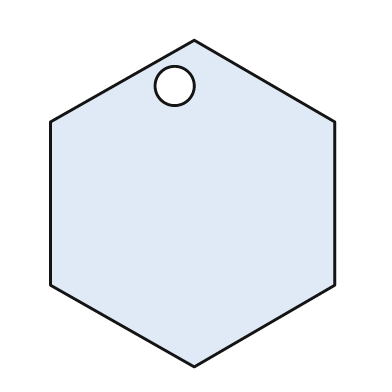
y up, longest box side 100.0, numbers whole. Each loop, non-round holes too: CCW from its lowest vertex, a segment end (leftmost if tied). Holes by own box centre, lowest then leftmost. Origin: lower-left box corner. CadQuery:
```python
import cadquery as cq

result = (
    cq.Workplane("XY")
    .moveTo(44.0, 0.0)
    .lineTo(87.0, 25.0)
    .lineTo(87.0, 75.0)
    .lineTo(44.0, 100.0)
    .lineTo(0.0, 75.0)
    .lineTo(0.0, 25.0)
    .close()
    .moveTo(38.0, 86.0)
    .circle(6.0)
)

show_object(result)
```